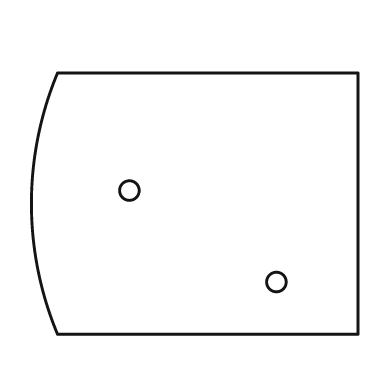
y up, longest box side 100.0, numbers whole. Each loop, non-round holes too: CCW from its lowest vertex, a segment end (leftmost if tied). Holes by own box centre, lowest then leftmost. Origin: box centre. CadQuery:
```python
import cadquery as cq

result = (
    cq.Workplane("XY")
    .moveTo(-42.0, -40.0)
    .lineTo(50.0, -40.0)
    .lineTo(50.0, 40.0)
    .lineTo(-42.0, 40.0)
    .threePointArc((-50.0, 0.0), (-42.0, -40.0))
    .close()
    .moveTo(25.0, -24.0)
    .circle(3.0)
    .moveTo(-20.0, 4.0)
    .circle(3.0)
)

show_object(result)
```